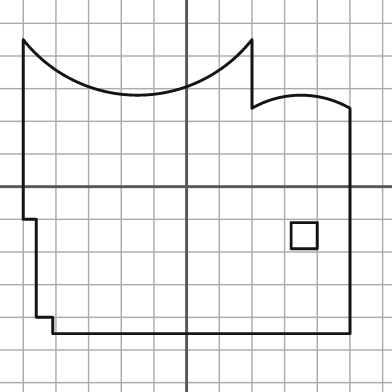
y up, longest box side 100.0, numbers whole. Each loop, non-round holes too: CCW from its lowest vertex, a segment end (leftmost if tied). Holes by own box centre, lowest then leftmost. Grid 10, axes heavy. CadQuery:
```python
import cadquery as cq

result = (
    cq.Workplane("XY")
    .moveTo(-41.0, -45.0)
    .lineTo(50.0, -45.0)
    .lineTo(50.0, 24.0)
    .threePointArc((35.0, 28.0), (20.0, 24.0))
    .lineTo(20.0, 45.0)
    .threePointArc((-15.0, 28.0), (-50.0, 45.0))
    .lineTo(-50.0, -10.0)
    .lineTo(-46.0, -10.0)
    .lineTo(-46.0, -40.0)
    .lineTo(-41.0, -40.0)
    .close()
    .moveTo(32.0, -19.0)
    .lineTo(40.0, -19.0)
    .lineTo(40.0, -11.0)
    .lineTo(32.0, -11.0)
    .close()
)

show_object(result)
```